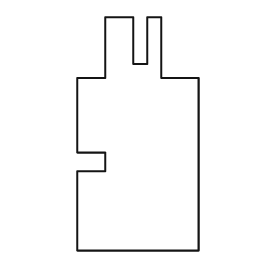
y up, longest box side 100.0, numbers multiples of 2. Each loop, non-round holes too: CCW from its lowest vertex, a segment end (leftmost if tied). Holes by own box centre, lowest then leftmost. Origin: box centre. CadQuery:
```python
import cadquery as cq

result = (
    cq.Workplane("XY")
    .moveTo(-26.0, -50.0)
    .lineTo(26.0, -50.0)
    .lineTo(26.0, 24.0)
    .lineTo(10.0, 24.0)
    .lineTo(10.0, 50.0)
    .lineTo(4.0, 50.0)
    .lineTo(4.0, 30.0)
    .lineTo(-2.0, 30.0)
    .lineTo(-2.0, 50.0)
    .lineTo(-14.0, 50.0)
    .lineTo(-14.0, 24.0)
    .lineTo(-26.0, 24.0)
    .lineTo(-26.0, -8.0)
    .lineTo(-14.0, -8.0)
    .lineTo(-14.0, -16.0)
    .lineTo(-26.0, -16.0)
    .close()
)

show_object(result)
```